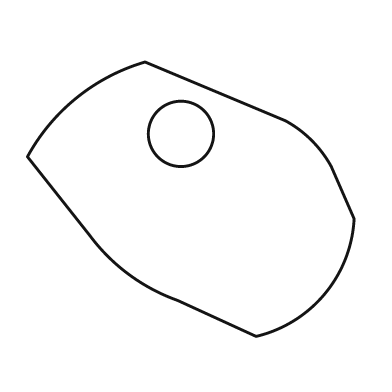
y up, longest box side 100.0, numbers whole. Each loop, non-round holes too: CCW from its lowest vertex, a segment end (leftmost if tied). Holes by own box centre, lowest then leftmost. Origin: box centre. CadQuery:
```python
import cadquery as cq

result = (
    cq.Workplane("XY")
    .moveTo(20.0, -42.0)
    .threePointArc((41.0, -29.0), (50.0, -6.0))
    .lineTo(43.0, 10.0)
    .threePointArc((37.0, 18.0), (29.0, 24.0))
    .lineTo(-14.0, 42.0)
    .threePointArc((-35.0, 31.0), (-50.0, 13.0))
    .lineTo(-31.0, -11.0)
    .threePointArc((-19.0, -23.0), (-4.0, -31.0))
    .close()
    .moveTo(-3.0, 20.0)
    .circle(10.0)
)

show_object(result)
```